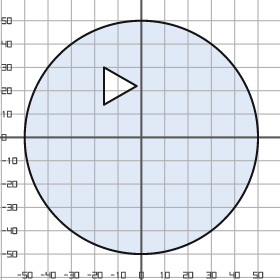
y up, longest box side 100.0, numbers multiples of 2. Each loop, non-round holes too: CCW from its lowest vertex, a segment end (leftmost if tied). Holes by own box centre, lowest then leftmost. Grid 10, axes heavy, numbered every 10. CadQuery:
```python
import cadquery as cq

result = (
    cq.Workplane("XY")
    .moveTo(0.0, 0.0)
    .circle(50.0)
    .moveTo(-16.0, 14.0)
    .lineTo(-2.0, 22.0)
    .lineTo(-16.0, 30.0)
    .close()
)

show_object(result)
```